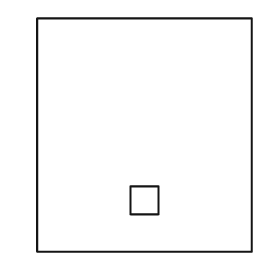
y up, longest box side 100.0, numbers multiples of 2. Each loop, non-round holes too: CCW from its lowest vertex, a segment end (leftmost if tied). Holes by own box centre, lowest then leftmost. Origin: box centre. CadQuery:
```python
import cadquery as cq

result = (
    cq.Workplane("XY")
    .moveTo(-46.0, -50.0)
    .lineTo(46.0, -50.0)
    .lineTo(46.0, 50.0)
    .lineTo(-46.0, 50.0)
    .close()
    .moveTo(-6.0, -34.0)
    .lineTo(6.0, -34.0)
    .lineTo(6.0, -22.0)
    .lineTo(-6.0, -22.0)
    .close()
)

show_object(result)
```